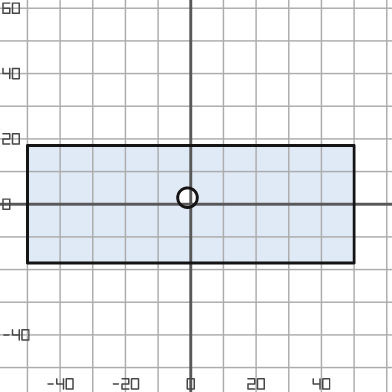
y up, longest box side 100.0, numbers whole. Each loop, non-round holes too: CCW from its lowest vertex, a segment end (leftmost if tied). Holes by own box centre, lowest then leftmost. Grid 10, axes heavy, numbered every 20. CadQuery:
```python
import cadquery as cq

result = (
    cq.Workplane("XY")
    .moveTo(-50.0, -18.0)
    .lineTo(50.0, -18.0)
    .lineTo(50.0, 18.0)
    .lineTo(-50.0, 18.0)
    .close()
    .moveTo(-1.0, 2.0)
    .circle(3.0)
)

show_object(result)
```